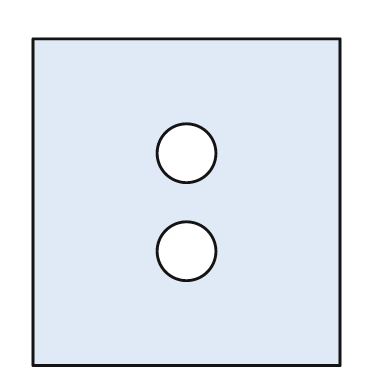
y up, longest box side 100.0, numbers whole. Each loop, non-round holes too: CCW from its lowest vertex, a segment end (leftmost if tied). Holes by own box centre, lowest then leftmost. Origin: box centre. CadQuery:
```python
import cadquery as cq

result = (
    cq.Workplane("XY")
    .moveTo(-47.0, -50.0)
    .lineTo(47.0, -50.0)
    .lineTo(47.0, 50.0)
    .lineTo(-47.0, 50.0)
    .close()
    .moveTo(0.0, -15.0)
    .circle(9.0)
    .moveTo(0.0, 15.0)
    .circle(9.0)
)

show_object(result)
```